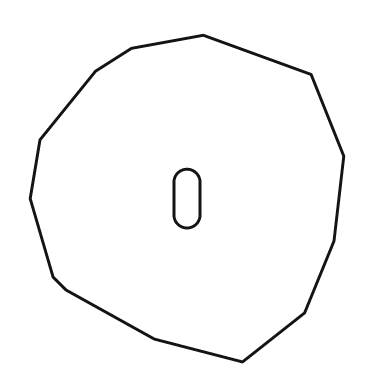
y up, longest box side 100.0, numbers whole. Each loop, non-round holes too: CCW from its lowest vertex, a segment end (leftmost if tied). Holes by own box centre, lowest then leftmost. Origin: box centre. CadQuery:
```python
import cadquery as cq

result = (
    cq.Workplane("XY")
    .moveTo(17.0, -50.0)
    .lineTo(36.0, -35.0)
    .lineTo(45.0, -13.0)
    .lineTo(48.0, 13.0)
    .lineTo(38.0, 38.0)
    .lineTo(5.0, 50.0)
    .lineTo(-17.0, 46.0)
    .lineTo(-28.0, 39.0)
    .lineTo(-45.0, 18.0)
    .lineTo(-48.0, 0.0)
    .lineTo(-41.0, -24.0)
    .lineTo(-37.0, -28.0)
    .lineTo(-10.0, -43.0)
    .close()
    .moveTo(-4.0, -5.0)
    .threePointArc((0.0, -9.0), (4.0, -5.0))
    .lineTo(4.0, 5.0)
    .threePointArc((0.0, 9.0), (-4.0, 5.0))
    .close()
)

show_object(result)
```